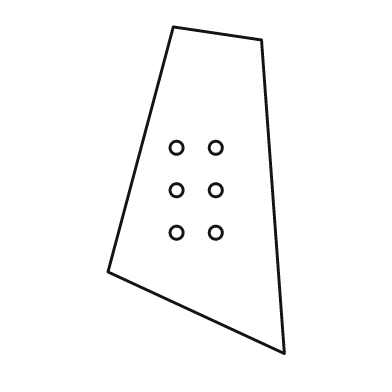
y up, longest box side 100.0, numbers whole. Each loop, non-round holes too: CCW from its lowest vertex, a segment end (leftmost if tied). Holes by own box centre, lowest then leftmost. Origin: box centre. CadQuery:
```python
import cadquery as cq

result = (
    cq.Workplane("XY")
    .moveTo(27.0, -50.0)
    .lineTo(20.0, 46.0)
    .lineTo(-7.0, 50.0)
    .lineTo(-27.0, -25.0)
    .close()
    .moveTo(-6.0, -13.0)
    .circle(2.0)
    .moveTo(6.0, -13.0)
    .circle(2.0)
    .moveTo(-6.0, 0.0)
    .circle(2.0)
    .moveTo(6.0, 0.0)
    .circle(2.0)
    .moveTo(-6.0, 13.0)
    .circle(2.0)
    .moveTo(6.0, 13.0)
    .circle(2.0)
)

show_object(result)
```